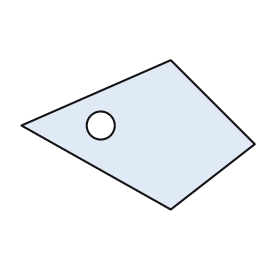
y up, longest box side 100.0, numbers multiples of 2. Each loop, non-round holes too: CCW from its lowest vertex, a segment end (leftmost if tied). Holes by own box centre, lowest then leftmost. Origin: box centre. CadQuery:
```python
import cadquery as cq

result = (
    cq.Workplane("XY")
    .moveTo(14.0, -32.0)
    .lineTo(50.0, -4.0)
    .lineTo(14.0, 32.0)
    .lineTo(-50.0, 4.0)
    .close()
    .moveTo(-16.0, 4.0)
    .circle(6.0)
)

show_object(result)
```